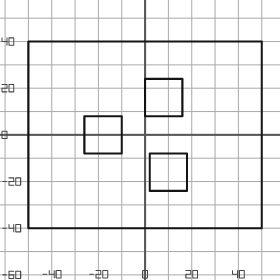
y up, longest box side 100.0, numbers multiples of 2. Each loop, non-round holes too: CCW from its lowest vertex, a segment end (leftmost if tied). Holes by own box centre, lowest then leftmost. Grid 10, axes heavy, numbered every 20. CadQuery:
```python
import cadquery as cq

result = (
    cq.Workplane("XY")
    .moveTo(-50.0, -40.0)
    .lineTo(50.0, -40.0)
    .lineTo(50.0, 40.0)
    .lineTo(-50.0, 40.0)
    .close()
    .moveTo(2.0, -24.0)
    .lineTo(18.0, -24.0)
    .lineTo(18.0, -8.0)
    .lineTo(2.0, -8.0)
    .close()
    .moveTo(-26.0, -8.0)
    .lineTo(-10.0, -8.0)
    .lineTo(-10.0, 8.0)
    .lineTo(-26.0, 8.0)
    .close()
    .moveTo(0.0, 8.0)
    .lineTo(16.0, 8.0)
    .lineTo(16.0, 24.0)
    .lineTo(0.0, 24.0)
    .close()
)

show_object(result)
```